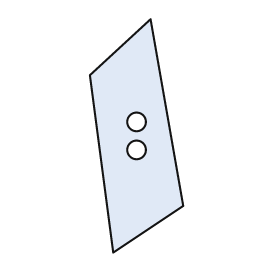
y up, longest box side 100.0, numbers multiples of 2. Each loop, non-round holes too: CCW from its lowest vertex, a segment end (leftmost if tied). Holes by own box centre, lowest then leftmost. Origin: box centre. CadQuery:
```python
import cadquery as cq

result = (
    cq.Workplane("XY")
    .moveTo(-10.0, -50.0)
    .lineTo(20.0, -30.0)
    .lineTo(6.0, 50.0)
    .lineTo(-20.0, 26.0)
    .close()
    .moveTo(0.0, -6.0)
    .circle(4.0)
    .moveTo(0.0, 6.0)
    .circle(4.0)
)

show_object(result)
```